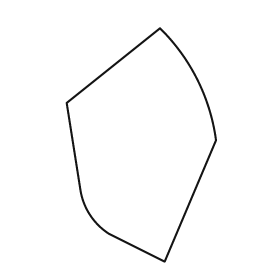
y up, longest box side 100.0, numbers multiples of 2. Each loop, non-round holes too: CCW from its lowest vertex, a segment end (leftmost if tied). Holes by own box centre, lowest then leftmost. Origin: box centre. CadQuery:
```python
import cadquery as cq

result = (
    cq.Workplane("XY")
    .moveTo(10.0, -50.0)
    .lineTo(32.0, 2.0)
    .threePointArc((24.0, 28.0), (8.0, 50.0))
    .lineTo(-32.0, 18.0)
    .lineTo(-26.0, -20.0)
    .threePointArc((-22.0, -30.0), (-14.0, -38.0))
    .close()
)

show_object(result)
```